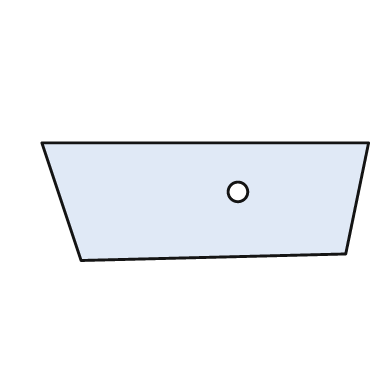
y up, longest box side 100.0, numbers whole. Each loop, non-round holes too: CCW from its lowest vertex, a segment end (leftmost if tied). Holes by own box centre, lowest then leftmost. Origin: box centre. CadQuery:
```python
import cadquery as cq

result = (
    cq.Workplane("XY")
    .moveTo(-38.0, -18.0)
    .lineTo(43.0, -16.0)
    .lineTo(50.0, 18.0)
    .lineTo(-50.0, 18.0)
    .close()
    .moveTo(10.0, 3.0)
    .circle(3.0)
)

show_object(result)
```